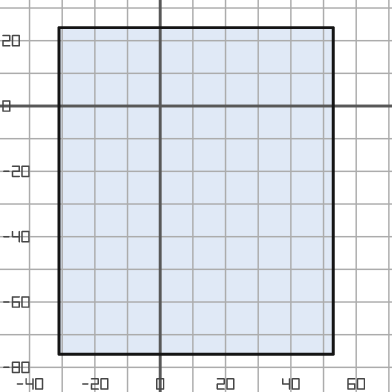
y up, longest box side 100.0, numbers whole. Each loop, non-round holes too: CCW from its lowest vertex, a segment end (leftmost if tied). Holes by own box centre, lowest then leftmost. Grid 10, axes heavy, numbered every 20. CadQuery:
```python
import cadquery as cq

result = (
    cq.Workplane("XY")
    .moveTo(-31.0, -76.0)
    .lineTo(53.0, -76.0)
    .lineTo(53.0, 24.0)
    .lineTo(-31.0, 24.0)
    .close()
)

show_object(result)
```